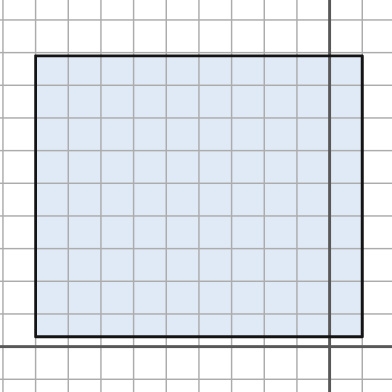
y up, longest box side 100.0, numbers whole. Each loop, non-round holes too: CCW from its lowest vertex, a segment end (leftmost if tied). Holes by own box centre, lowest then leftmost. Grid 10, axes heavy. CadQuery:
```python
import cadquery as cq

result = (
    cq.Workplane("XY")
    .moveTo(-90.0, 3.0)
    .lineTo(10.0, 3.0)
    .lineTo(10.0, 89.0)
    .lineTo(-90.0, 89.0)
    .close()
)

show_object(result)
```